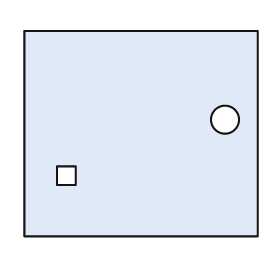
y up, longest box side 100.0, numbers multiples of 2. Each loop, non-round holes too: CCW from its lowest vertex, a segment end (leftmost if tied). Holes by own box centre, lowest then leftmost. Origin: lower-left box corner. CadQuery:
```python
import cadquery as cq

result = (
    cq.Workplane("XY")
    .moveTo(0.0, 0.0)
    .lineTo(100.0, 0.0)
    .lineTo(100.0, 88.0)
    .lineTo(0.0, 88.0)
    .close()
    .moveTo(14.0, 22.0)
    .lineTo(22.0, 22.0)
    .lineTo(22.0, 30.0)
    .lineTo(14.0, 30.0)
    .close()
    .moveTo(86.0, 50.0)
    .circle(6.0)
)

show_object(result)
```